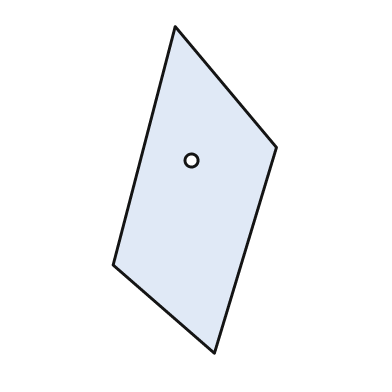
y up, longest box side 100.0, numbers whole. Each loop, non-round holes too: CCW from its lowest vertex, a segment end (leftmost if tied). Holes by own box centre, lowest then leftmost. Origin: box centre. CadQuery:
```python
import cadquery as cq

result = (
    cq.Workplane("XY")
    .moveTo(6.0, -50.0)
    .lineTo(25.0, 13.0)
    .lineTo(-6.0, 50.0)
    .lineTo(-25.0, -23.0)
    .close()
    .moveTo(-1.0, 9.0)
    .circle(2.0)
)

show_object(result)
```